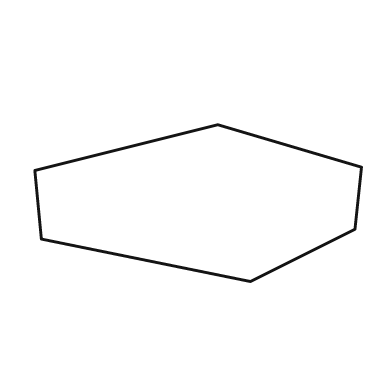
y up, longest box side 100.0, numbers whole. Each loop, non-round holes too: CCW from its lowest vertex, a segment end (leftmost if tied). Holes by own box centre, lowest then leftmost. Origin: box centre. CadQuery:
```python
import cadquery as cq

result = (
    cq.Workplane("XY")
    .moveTo(16.0, -24.0)
    .lineTo(48.0, -8.0)
    .lineTo(50.0, 11.0)
    .lineTo(6.0, 24.0)
    .lineTo(-50.0, 10.0)
    .lineTo(-48.0, -11.0)
    .close()
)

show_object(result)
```